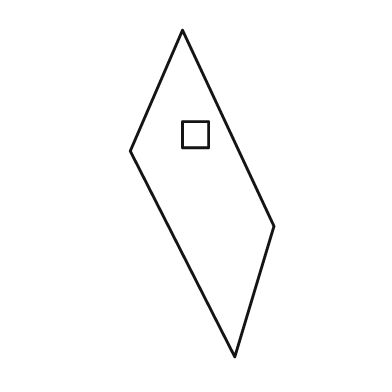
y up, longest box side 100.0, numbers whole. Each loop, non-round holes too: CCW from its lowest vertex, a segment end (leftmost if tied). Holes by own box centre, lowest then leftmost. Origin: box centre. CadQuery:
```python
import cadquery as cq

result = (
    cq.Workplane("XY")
    .moveTo(10.0, -50.0)
    .lineTo(22.0, -10.0)
    .lineTo(-6.0, 50.0)
    .lineTo(-22.0, 13.0)
    .close()
    .moveTo(-6.0, 14.0)
    .lineTo(2.0, 14.0)
    .lineTo(2.0, 22.0)
    .lineTo(-6.0, 22.0)
    .close()
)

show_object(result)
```